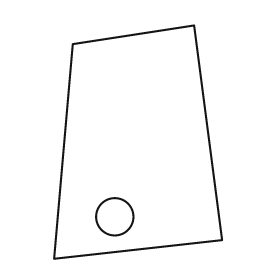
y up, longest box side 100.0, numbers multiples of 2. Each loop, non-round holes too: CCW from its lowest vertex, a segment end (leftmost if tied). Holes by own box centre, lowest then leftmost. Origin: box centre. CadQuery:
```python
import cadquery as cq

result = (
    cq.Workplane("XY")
    .moveTo(-36.0, -50.0)
    .lineTo(36.0, -42.0)
    .lineTo(24.0, 50.0)
    .lineTo(-28.0, 42.0)
    .close()
    .moveTo(-10.0, -32.0)
    .circle(8.0)
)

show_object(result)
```